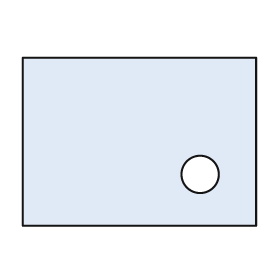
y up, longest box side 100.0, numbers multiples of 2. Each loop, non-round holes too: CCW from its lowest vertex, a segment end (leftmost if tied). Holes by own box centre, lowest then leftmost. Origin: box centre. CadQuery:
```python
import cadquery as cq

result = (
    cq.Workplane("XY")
    .moveTo(-50.0, -36.0)
    .lineTo(50.0, -36.0)
    .lineTo(50.0, 36.0)
    .lineTo(-50.0, 36.0)
    .close()
    .moveTo(26.0, -14.0)
    .circle(8.0)
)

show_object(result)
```